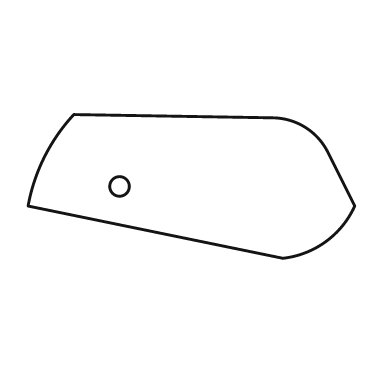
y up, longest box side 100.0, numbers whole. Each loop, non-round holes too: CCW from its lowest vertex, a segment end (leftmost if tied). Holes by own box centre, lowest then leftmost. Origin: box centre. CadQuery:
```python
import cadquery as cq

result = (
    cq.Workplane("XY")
    .moveTo(28.0, -22.0)
    .threePointArc((41.0, -17.0), (50.0, -6.0))
    .lineTo(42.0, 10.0)
    .threePointArc((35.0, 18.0), (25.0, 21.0))
    .lineTo(-36.0, 22.0)
    .threePointArc((-45.0, 9.0), (-50.0, -6.0))
    .close()
    .moveTo(-22.0, 0.0)
    .circle(3.0)
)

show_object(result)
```